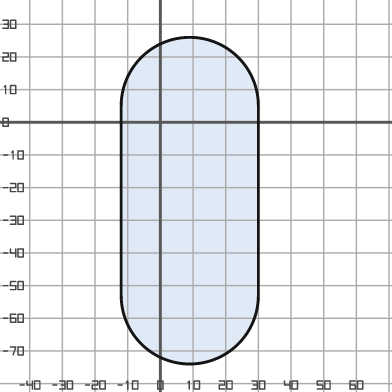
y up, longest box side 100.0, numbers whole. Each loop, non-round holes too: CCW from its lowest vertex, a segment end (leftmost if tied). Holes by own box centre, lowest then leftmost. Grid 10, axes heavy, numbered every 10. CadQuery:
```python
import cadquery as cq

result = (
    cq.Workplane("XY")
    .moveTo(-12.0, -53.0)
    .threePointArc((9.0, -74.0), (30.0, -53.0))
    .lineTo(30.0, 5.0)
    .threePointArc((9.0, 26.0), (-12.0, 5.0))
    .close()
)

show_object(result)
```